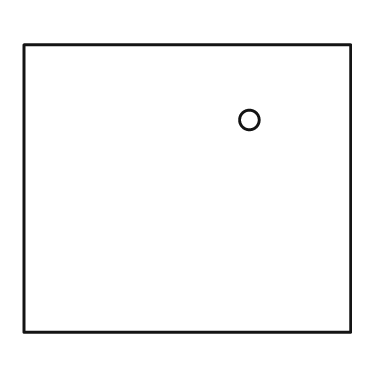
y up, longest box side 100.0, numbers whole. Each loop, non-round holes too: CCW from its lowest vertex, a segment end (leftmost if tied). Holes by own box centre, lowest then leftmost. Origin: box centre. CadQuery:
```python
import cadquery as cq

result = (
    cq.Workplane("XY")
    .moveTo(-50.0, -44.0)
    .lineTo(50.0, -44.0)
    .lineTo(50.0, 44.0)
    .lineTo(-50.0, 44.0)
    .close()
    .moveTo(19.0, 21.0)
    .circle(3.0)
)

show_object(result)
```